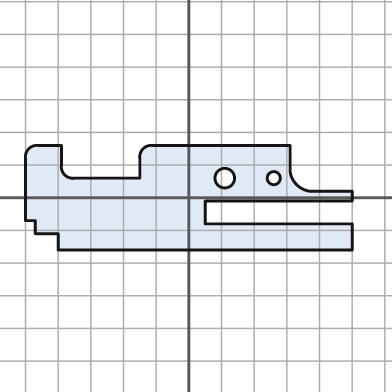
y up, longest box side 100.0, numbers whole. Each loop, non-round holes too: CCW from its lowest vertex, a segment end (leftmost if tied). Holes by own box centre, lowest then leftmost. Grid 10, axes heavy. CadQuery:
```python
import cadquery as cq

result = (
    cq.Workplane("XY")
    .moveTo(-40.0, -16.0)
    .lineTo(50.0, -16.0)
    .lineTo(50.0, -8.0)
    .lineTo(5.0, -8.0)
    .lineTo(5.0, -1.0)
    .lineTo(50.0, -1.0)
    .lineTo(50.0, 2.0)
    .lineTo(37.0, 2.0)
    .threePointArc((33.0, 4.0), (31.0, 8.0))
    .lineTo(31.0, 16.0)
    .lineTo(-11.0, 16.0)
    .threePointArc((-14.0, 15.0), (-15.0, 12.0))
    .lineTo(-15.0, 6.0)
    .lineTo(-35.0, 6.0)
    .threePointArc((-38.0, 7.0), (-39.0, 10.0))
    .lineTo(-39.0, 16.0)
    .lineTo(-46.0, 16.0)
    .threePointArc((-49.0, 15.0), (-50.0, 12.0))
    .lineTo(-50.0, -7.0)
    .lineTo(-47.0, -7.0)
    .lineTo(-47.0, -11.0)
    .lineTo(-40.0, -11.0)
    .close()
    .moveTo(11.0, 6.0)
    .circle(3.0)
    .moveTo(26.0, 6.0)
    .circle(2.0)
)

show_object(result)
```